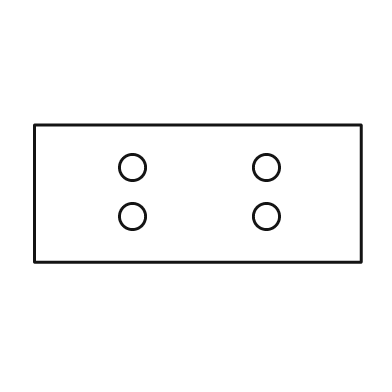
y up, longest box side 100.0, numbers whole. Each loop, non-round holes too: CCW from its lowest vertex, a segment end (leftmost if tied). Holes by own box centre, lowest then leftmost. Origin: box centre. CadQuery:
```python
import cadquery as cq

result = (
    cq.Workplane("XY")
    .moveTo(-50.0, -21.0)
    .lineTo(50.0, -21.0)
    .lineTo(50.0, 21.0)
    .lineTo(-50.0, 21.0)
    .close()
    .moveTo(-20.0, -7.0)
    .circle(4.0)
    .moveTo(21.0, -7.0)
    .circle(4.0)
    .moveTo(-20.0, 8.0)
    .circle(4.0)
    .moveTo(21.0, 8.0)
    .circle(4.0)
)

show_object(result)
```